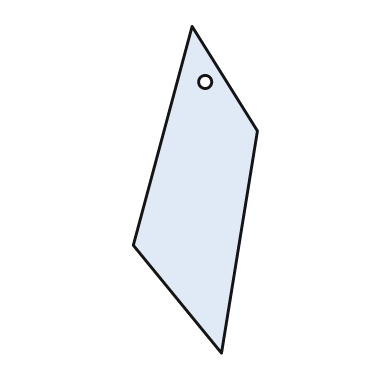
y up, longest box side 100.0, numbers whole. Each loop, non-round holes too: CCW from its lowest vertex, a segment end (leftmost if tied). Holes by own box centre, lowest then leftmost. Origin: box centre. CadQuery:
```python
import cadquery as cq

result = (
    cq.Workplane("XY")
    .moveTo(8.0, -50.0)
    .lineTo(19.0, 18.0)
    .lineTo(-1.0, 50.0)
    .lineTo(-19.0, -17.0)
    .close()
    .moveTo(3.0, 33.0)
    .circle(2.0)
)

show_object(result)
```